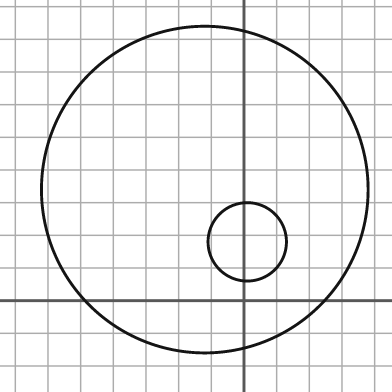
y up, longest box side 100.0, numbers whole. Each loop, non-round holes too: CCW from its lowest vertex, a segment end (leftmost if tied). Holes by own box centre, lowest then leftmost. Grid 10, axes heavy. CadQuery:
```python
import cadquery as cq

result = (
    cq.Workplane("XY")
    .moveTo(-12.0, 34.0)
    .circle(50.0)
    .moveTo(1.0, 18.0)
    .circle(12.0)
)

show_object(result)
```